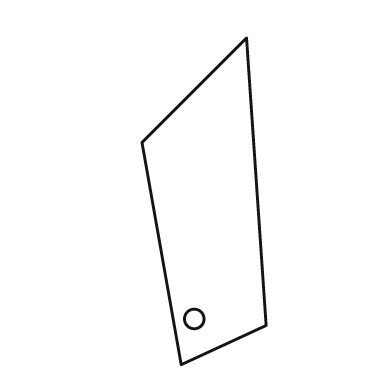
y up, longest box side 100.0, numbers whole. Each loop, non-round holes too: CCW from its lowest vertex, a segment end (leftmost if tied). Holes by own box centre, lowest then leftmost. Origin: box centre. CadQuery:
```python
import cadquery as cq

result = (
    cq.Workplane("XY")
    .moveTo(-7.0, -50.0)
    .lineTo(19.0, -38.0)
    .lineTo(13.0, 50.0)
    .lineTo(-19.0, 18.0)
    .close()
    .moveTo(-3.0, -36.0)
    .circle(3.0)
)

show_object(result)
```